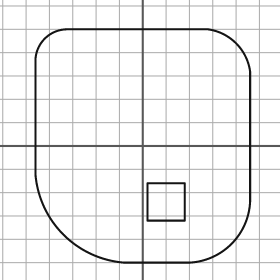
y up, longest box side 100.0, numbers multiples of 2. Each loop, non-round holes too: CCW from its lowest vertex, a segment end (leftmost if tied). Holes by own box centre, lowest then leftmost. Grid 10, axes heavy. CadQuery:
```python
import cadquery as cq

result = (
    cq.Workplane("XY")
    .moveTo(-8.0, -50.0)
    .lineTo(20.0, -50.0)
    .threePointArc((38.0, -42.0), (46.0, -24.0))
    .lineTo(46.0, 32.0)
    .threePointArc((40.0, 44.0), (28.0, 50.0))
    .lineTo(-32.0, 50.0)
    .threePointArc((-42.0, 46.0), (-46.0, 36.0))
    .lineTo(-46.0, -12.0)
    .threePointArc((-34.0, -38.0), (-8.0, -50.0))
    .close()
    .moveTo(2.0, -32.0)
    .lineTo(18.0, -32.0)
    .lineTo(18.0, -16.0)
    .lineTo(2.0, -16.0)
    .close()
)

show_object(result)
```